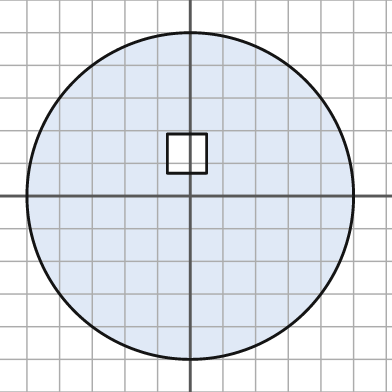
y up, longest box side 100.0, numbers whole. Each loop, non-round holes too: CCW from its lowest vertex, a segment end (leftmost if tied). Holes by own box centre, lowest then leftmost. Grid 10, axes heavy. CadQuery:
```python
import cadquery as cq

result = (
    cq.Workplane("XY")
    .moveTo(0.0, 0.0)
    .circle(50.0)
    .moveTo(-7.0, 7.0)
    .lineTo(5.0, 7.0)
    .lineTo(5.0, 19.0)
    .lineTo(-7.0, 19.0)
    .close()
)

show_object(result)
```